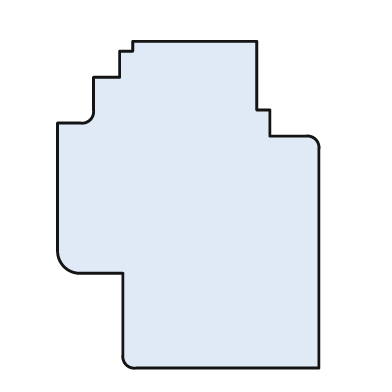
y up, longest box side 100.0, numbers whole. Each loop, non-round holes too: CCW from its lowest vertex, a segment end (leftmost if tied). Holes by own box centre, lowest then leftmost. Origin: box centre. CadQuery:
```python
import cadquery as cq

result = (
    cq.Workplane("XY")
    .moveTo(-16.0, -50.0)
    .lineTo(40.0, -50.0)
    .lineTo(40.0, 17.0)
    .threePointArc((39.0, 20.0), (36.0, 21.0))
    .lineTo(25.0, 21.0)
    .lineTo(25.0, 29.0)
    .lineTo(21.0, 29.0)
    .lineTo(21.0, 50.0)
    .lineTo(-17.0, 50.0)
    .lineTo(-17.0, 47.0)
    .lineTo(-21.0, 47.0)
    .lineTo(-21.0, 39.0)
    .lineTo(-29.0, 39.0)
    .lineTo(-29.0, 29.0)
    .threePointArc((-30.0, 26.0), (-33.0, 25.0))
    .lineTo(-40.0, 25.0)
    .lineTo(-40.0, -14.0)
    .threePointArc((-38.0, -19.0), (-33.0, -21.0))
    .lineTo(-20.0, -21.0)
    .lineTo(-20.0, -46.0)
    .threePointArc((-19.0, -49.0), (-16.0, -50.0))
    .close()
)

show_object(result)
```